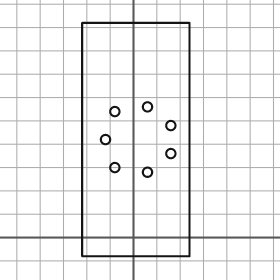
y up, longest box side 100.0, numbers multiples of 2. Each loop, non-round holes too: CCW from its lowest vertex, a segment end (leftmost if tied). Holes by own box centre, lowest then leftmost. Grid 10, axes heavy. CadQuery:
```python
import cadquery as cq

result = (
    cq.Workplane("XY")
    .moveTo(-22.0, -8.0)
    .lineTo(24.0, -8.0)
    .lineTo(24.0, 92.0)
    .lineTo(-22.0, 92.0)
    .close()
    .moveTo(6.0, 28.0)
    .circle(2.0)
    .moveTo(-8.0, 30.0)
    .circle(2.0)
    .moveTo(16.0, 36.0)
    .circle(2.0)
    .moveTo(-12.0, 42.0)
    .circle(2.0)
    .moveTo(16.0, 48.0)
    .circle(2.0)
    .moveTo(-8.0, 54.0)
    .circle(2.0)
    .moveTo(6.0, 56.0)
    .circle(2.0)
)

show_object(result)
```